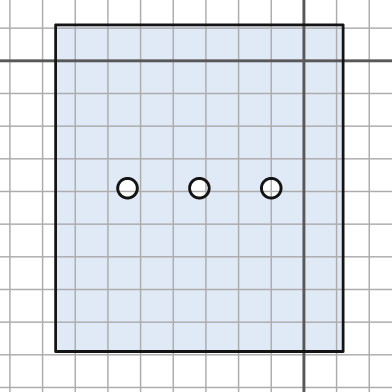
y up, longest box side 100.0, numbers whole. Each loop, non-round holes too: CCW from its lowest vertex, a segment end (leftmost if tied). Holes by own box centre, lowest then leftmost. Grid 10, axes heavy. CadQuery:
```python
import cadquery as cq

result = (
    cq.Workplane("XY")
    .moveTo(-76.0, -89.0)
    .lineTo(12.0, -89.0)
    .lineTo(12.0, 11.0)
    .lineTo(-76.0, 11.0)
    .close()
    .moveTo(-54.0, -39.0)
    .circle(3.0)
    .moveTo(-32.0, -39.0)
    .circle(3.0)
    .moveTo(-10.0, -39.0)
    .circle(3.0)
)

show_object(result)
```